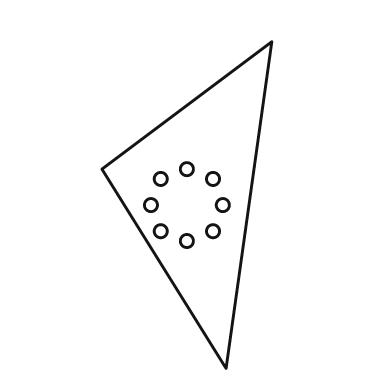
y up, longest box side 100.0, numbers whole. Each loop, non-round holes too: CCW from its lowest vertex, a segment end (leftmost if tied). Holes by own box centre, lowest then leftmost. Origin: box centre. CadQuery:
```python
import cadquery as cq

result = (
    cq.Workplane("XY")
    .moveTo(12.0, -50.0)
    .lineTo(26.0, 50.0)
    .lineTo(-26.0, 11.0)
    .close()
    .moveTo(0.0, -11.0)
    .circle(2.0)
    .moveTo(-8.0, -8.0)
    .circle(2.0)
    .moveTo(8.0, -8.0)
    .circle(2.0)
    .moveTo(-11.0, 0.0)
    .circle(2.0)
    .moveTo(11.0, 0.0)
    .circle(2.0)
    .moveTo(-8.0, 8.0)
    .circle(2.0)
    .moveTo(8.0, 8.0)
    .circle(2.0)
    .moveTo(0.0, 11.0)
    .circle(2.0)
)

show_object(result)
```